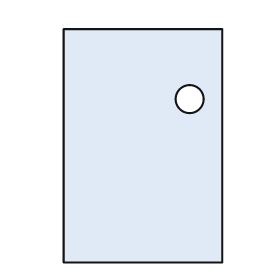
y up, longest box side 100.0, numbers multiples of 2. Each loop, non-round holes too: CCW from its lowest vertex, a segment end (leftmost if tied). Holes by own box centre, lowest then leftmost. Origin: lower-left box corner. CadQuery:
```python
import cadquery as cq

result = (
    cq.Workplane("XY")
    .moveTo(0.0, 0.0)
    .lineTo(68.0, 0.0)
    .lineTo(68.0, 100.0)
    .lineTo(0.0, 100.0)
    .close()
    .moveTo(54.0, 70.0)
    .circle(6.0)
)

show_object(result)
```